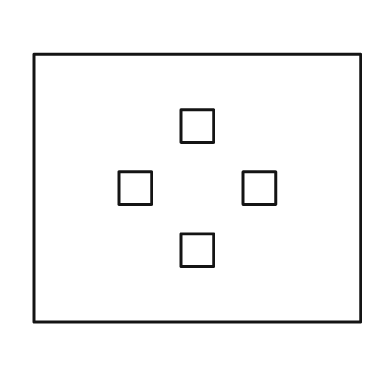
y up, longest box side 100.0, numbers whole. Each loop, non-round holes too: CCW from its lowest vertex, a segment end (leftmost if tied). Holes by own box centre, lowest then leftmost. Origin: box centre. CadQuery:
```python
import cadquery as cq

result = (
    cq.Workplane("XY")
    .moveTo(-50.0, -41.0)
    .lineTo(50.0, -41.0)
    .lineTo(50.0, 41.0)
    .lineTo(-50.0, 41.0)
    .close()
    .moveTo(-5.0, -24.0)
    .lineTo(5.0, -24.0)
    .lineTo(5.0, -14.0)
    .lineTo(-5.0, -14.0)
    .close()
    .moveTo(-24.0, -5.0)
    .lineTo(-14.0, -5.0)
    .lineTo(-14.0, 5.0)
    .lineTo(-24.0, 5.0)
    .close()
    .moveTo(14.0, -5.0)
    .lineTo(24.0, -5.0)
    .lineTo(24.0, 5.0)
    .lineTo(14.0, 5.0)
    .close()
    .moveTo(-5.0, 14.0)
    .lineTo(5.0, 14.0)
    .lineTo(5.0, 24.0)
    .lineTo(-5.0, 24.0)
    .close()
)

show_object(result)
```